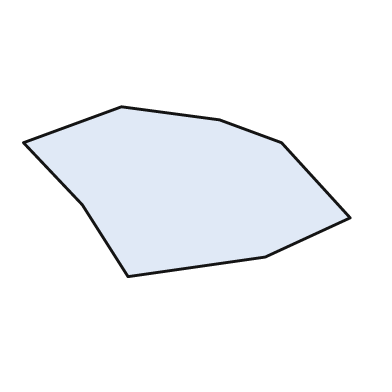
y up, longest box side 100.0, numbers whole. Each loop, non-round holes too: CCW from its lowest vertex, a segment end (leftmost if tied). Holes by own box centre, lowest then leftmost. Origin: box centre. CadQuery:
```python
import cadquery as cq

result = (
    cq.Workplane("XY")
    .moveTo(-18.0, -26.0)
    .lineTo(24.0, -20.0)
    .lineTo(50.0, -8.0)
    .lineTo(29.0, 15.0)
    .lineTo(10.0, 22.0)
    .lineTo(-20.0, 26.0)
    .lineTo(-50.0, 15.0)
    .lineTo(-32.0, -4.0)
    .close()
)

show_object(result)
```